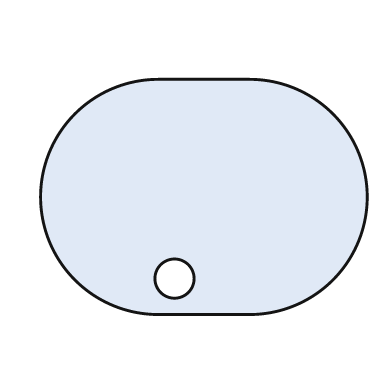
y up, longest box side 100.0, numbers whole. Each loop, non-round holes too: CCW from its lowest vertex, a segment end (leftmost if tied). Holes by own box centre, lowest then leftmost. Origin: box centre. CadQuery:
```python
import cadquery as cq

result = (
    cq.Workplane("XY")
    .moveTo(-14.0, -36.0)
    .lineTo(14.0, -36.0)
    .threePointArc((50.0, 0.0), (14.0, 36.0))
    .lineTo(-14.0, 36.0)
    .threePointArc((-50.0, 0.0), (-14.0, -36.0))
    .close()
    .moveTo(-9.0, -25.0)
    .circle(6.0)
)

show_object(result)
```